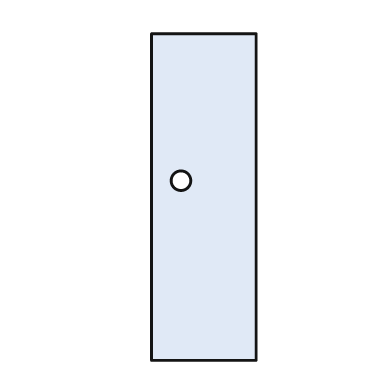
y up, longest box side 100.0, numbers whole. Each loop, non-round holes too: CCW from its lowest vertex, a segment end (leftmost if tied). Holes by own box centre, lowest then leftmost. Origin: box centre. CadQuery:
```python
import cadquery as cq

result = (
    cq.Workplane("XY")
    .moveTo(-16.0, -50.0)
    .lineTo(16.0, -50.0)
    .lineTo(16.0, 50.0)
    .lineTo(-16.0, 50.0)
    .close()
    .moveTo(-7.0, 5.0)
    .circle(3.0)
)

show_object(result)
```